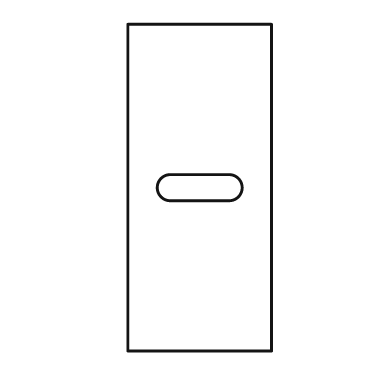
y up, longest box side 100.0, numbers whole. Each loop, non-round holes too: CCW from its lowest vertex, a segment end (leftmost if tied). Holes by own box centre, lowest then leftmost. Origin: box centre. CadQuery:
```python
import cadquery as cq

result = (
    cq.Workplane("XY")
    .moveTo(-22.0, -50.0)
    .lineTo(22.0, -50.0)
    .lineTo(22.0, 50.0)
    .lineTo(-22.0, 50.0)
    .close()
    .moveTo(-9.0, -4.0)
    .lineTo(9.0, -4.0)
    .threePointArc((13.0, 0.0), (9.0, 4.0))
    .lineTo(-9.0, 4.0)
    .threePointArc((-13.0, 0.0), (-9.0, -4.0))
    .close()
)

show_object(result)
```